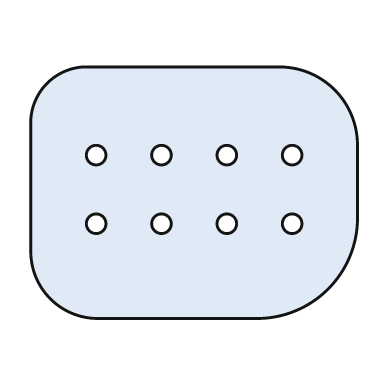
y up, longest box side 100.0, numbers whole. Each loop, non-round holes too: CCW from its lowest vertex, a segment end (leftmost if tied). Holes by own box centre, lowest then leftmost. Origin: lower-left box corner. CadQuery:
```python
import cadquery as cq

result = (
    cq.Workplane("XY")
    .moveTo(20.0, 0.0)
    .lineTo(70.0, 0.0)
    .threePointArc((91.0, 9.0), (100.0, 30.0))
    .lineTo(100.0, 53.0)
    .threePointArc((93.0, 70.0), (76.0, 77.0))
    .lineTo(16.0, 77.0)
    .threePointArc((5.0, 72.0), (0.0, 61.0))
    .lineTo(0.0, 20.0)
    .threePointArc((6.0, 6.0), (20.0, 0.0))
    .close()
    .moveTo(20.0, 29.0)
    .circle(3.0)
    .moveTo(40.0, 29.0)
    .circle(3.0)
    .moveTo(60.0, 29.0)
    .circle(3.0)
    .moveTo(80.0, 29.0)
    .circle(3.0)
    .moveTo(20.0, 50.0)
    .circle(3.0)
    .moveTo(40.0, 50.0)
    .circle(3.0)
    .moveTo(60.0, 50.0)
    .circle(3.0)
    .moveTo(80.0, 50.0)
    .circle(3.0)
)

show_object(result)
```